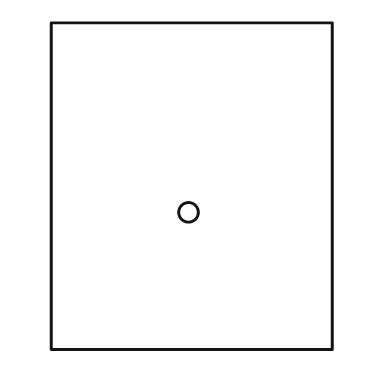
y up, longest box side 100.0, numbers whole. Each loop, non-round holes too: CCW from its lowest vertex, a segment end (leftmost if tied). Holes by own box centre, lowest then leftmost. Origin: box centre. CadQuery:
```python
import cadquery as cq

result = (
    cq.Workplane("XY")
    .moveTo(-43.0, -50.0)
    .lineTo(43.0, -50.0)
    .lineTo(43.0, 50.0)
    .lineTo(-43.0, 50.0)
    .close()
    .moveTo(-1.0, -8.0)
    .circle(3.0)
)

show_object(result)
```